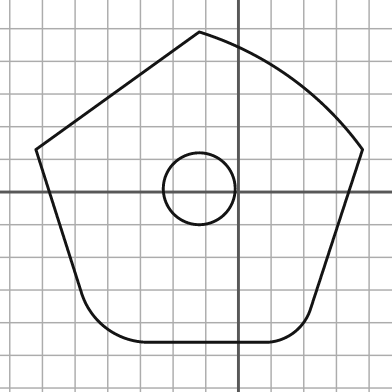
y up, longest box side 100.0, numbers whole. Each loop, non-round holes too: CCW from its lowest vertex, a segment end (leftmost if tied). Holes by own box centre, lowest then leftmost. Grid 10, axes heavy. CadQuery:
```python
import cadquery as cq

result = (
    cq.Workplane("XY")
    .moveTo(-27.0, -46.0)
    .lineTo(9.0, -46.0)
    .threePointArc((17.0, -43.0), (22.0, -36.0))
    .lineTo(38.0, 13.0)
    .threePointArc((16.0, 35.0), (-12.0, 49.0))
    .lineTo(-62.0, 13.0)
    .lineTo(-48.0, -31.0)
    .threePointArc((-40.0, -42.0), (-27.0, -46.0))
    .close()
    .moveTo(-12.0, 1.0)
    .circle(11.0)
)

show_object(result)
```